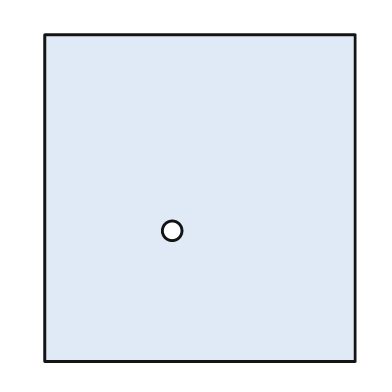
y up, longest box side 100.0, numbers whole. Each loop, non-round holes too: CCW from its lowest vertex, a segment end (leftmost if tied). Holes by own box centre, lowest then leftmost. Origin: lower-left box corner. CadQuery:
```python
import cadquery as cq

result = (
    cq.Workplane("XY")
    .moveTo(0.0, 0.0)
    .lineTo(95.0, 0.0)
    .lineTo(95.0, 100.0)
    .lineTo(0.0, 100.0)
    .close()
    .moveTo(39.0, 40.0)
    .circle(3.0)
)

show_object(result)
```